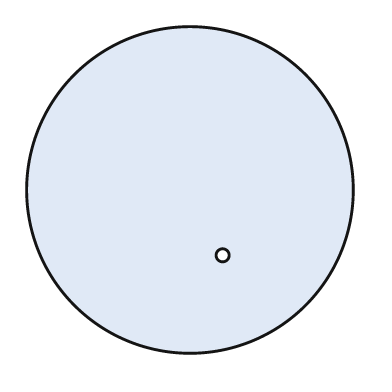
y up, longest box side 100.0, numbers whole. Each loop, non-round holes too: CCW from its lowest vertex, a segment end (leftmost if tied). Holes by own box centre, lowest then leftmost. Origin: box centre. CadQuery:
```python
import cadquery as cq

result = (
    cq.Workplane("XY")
    .moveTo(0.0, 0.0)
    .circle(50.0)
    .moveTo(10.0, -20.0)
    .circle(2.0)
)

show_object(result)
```